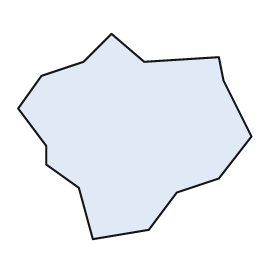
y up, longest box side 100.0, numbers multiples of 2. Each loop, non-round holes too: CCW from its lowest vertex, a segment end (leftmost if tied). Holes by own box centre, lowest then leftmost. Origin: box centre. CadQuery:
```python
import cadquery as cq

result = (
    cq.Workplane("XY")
    .moveTo(-18.0, -44.0)
    .lineTo(6.0, -40.0)
    .lineTo(18.0, -24.0)
    .lineTo(36.0, -18.0)
    .lineTo(50.0, 0.0)
    .lineTo(38.0, 24.0)
    .lineTo(36.0, 34.0)
    .lineTo(4.0, 32.0)
    .lineTo(-10.0, 44.0)
    .lineTo(-22.0, 32.0)
    .lineTo(-40.0, 26.0)
    .lineTo(-50.0, 12.0)
    .lineTo(-38.0, -4.0)
    .lineTo(-38.0, -12.0)
    .lineTo(-24.0, -22.0)
    .close()
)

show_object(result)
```